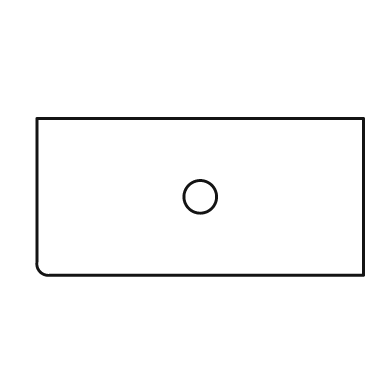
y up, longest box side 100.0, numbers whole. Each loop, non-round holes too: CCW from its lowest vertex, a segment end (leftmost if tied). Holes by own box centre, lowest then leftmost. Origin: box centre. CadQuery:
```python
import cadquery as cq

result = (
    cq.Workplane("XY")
    .moveTo(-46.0, -24.0)
    .lineTo(50.0, -24.0)
    .lineTo(50.0, 24.0)
    .lineTo(-50.0, 24.0)
    .lineTo(-50.0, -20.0)
    .threePointArc((-49.0, -23.0), (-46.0, -24.0))
    .close()
    .moveTo(0.0, 0.0)
    .circle(5.0)
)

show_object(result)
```